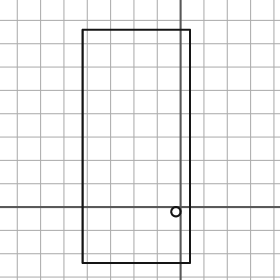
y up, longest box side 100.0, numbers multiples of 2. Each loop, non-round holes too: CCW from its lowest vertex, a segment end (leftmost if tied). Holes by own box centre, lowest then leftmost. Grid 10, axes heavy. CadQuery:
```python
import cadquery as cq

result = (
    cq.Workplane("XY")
    .moveTo(-42.0, -24.0)
    .lineTo(4.0, -24.0)
    .lineTo(4.0, 76.0)
    .lineTo(-42.0, 76.0)
    .close()
    .moveTo(-2.0, -2.0)
    .circle(2.0)
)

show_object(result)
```